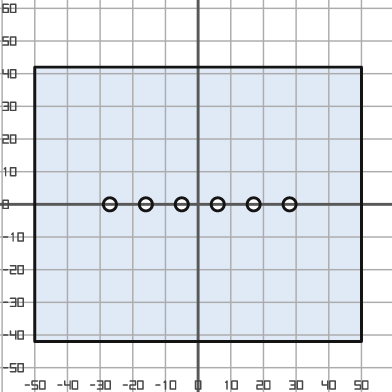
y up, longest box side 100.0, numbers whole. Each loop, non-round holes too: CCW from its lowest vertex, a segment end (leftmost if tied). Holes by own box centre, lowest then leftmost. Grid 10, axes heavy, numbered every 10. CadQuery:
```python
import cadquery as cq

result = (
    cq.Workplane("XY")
    .moveTo(-50.0, -42.0)
    .lineTo(50.0, -42.0)
    .lineTo(50.0, 42.0)
    .lineTo(-50.0, 42.0)
    .close()
    .moveTo(-27.0, 0.0)
    .circle(2.0)
    .moveTo(-16.0, 0.0)
    .circle(2.0)
    .moveTo(-5.0, 0.0)
    .circle(2.0)
    .moveTo(6.0, 0.0)
    .circle(2.0)
    .moveTo(17.0, 0.0)
    .circle(2.0)
    .moveTo(28.0, 0.0)
    .circle(2.0)
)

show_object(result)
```